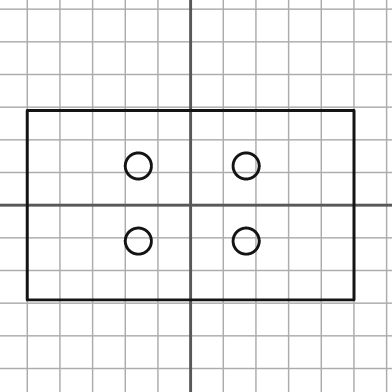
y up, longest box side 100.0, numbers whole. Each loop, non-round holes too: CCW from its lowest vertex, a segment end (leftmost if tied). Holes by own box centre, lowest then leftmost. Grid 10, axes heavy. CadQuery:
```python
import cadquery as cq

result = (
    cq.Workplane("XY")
    .moveTo(-50.0, -29.0)
    .lineTo(50.0, -29.0)
    .lineTo(50.0, 29.0)
    .lineTo(-50.0, 29.0)
    .close()
    .moveTo(-16.0, -11.0)
    .circle(4.0)
    .moveTo(17.0, -11.0)
    .circle(4.0)
    .moveTo(-16.0, 12.0)
    .circle(4.0)
    .moveTo(17.0, 12.0)
    .circle(4.0)
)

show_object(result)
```